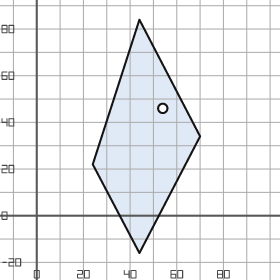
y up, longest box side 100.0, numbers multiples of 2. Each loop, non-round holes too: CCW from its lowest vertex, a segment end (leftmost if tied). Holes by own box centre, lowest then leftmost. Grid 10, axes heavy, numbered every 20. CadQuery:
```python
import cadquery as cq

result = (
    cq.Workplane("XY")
    .moveTo(44.0, -16.0)
    .lineTo(70.0, 34.0)
    .lineTo(44.0, 84.0)
    .lineTo(24.0, 22.0)
    .close()
    .moveTo(54.0, 46.0)
    .circle(2.0)
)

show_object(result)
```